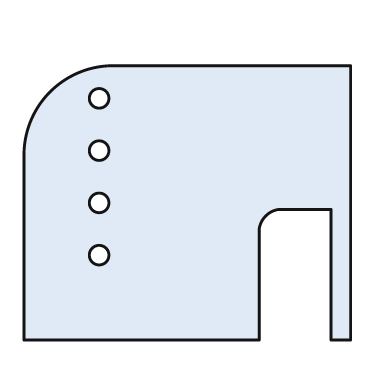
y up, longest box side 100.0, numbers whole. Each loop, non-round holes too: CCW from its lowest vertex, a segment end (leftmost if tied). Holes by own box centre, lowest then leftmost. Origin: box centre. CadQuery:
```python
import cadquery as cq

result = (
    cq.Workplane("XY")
    .moveTo(-50.0, -42.0)
    .lineTo(22.0, -42.0)
    .lineTo(22.0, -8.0)
    .threePointArc((24.0, -4.0), (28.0, -2.0))
    .lineTo(44.0, -2.0)
    .lineTo(44.0, -42.0)
    .lineTo(50.0, -42.0)
    .lineTo(50.0, 42.0)
    .lineTo(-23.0, 42.0)
    .threePointArc((-42.0, 34.0), (-50.0, 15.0))
    .close()
    .moveTo(-27.0, -16.0)
    .circle(3.0)
    .moveTo(-27.0, 0.0)
    .circle(3.0)
    .moveTo(-27.0, 16.0)
    .circle(3.0)
    .moveTo(-27.0, 32.0)
    .circle(3.0)
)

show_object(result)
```